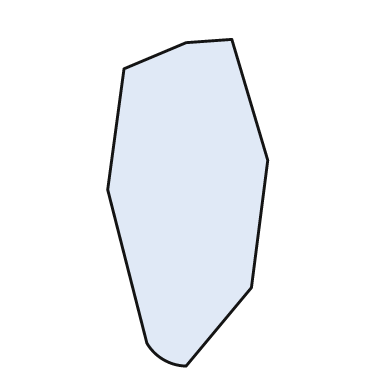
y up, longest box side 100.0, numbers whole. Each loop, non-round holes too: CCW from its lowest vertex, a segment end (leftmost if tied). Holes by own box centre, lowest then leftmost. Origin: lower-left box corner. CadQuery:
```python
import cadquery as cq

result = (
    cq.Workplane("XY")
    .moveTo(24.0, 0.0)
    .lineTo(44.0, 24.0)
    .lineTo(49.0, 63.0)
    .lineTo(38.0, 100.0)
    .lineTo(24.0, 99.0)
    .lineTo(5.0, 91.0)
    .lineTo(0.0, 54.0)
    .lineTo(12.0, 7.0)
    .threePointArc((17.0, 2.0), (24.0, 0.0))
    .close()
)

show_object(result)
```